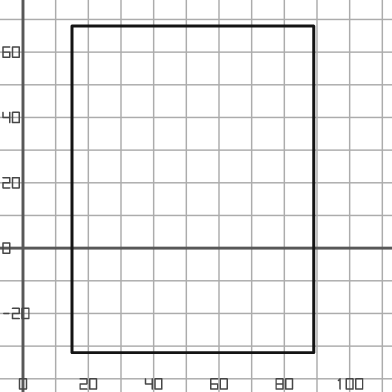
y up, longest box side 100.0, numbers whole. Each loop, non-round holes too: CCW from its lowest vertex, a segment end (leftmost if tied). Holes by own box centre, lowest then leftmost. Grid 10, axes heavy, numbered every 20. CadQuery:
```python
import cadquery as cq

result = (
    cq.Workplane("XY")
    .moveTo(15.0, -32.0)
    .lineTo(89.0, -32.0)
    .lineTo(89.0, 68.0)
    .lineTo(15.0, 68.0)
    .close()
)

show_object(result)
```